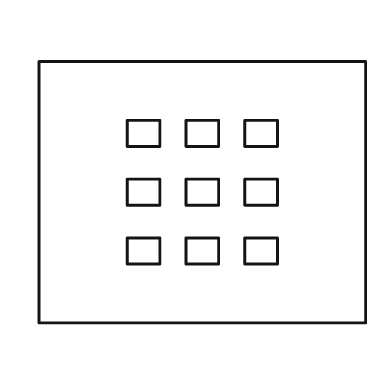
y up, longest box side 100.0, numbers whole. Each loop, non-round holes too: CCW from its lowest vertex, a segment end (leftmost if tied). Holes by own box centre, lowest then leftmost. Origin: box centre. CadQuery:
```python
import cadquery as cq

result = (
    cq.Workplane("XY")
    .moveTo(-50.0, -40.0)
    .lineTo(50.0, -40.0)
    .lineTo(50.0, 40.0)
    .lineTo(-50.0, 40.0)
    .close()
    .moveTo(-23.0, -22.0)
    .lineTo(-13.0, -22.0)
    .lineTo(-13.0, -14.0)
    .lineTo(-23.0, -14.0)
    .close()
    .moveTo(-5.0, -22.0)
    .lineTo(5.0, -22.0)
    .lineTo(5.0, -14.0)
    .lineTo(-5.0, -14.0)
    .close()
    .moveTo(13.0, -22.0)
    .lineTo(23.0, -22.0)
    .lineTo(23.0, -14.0)
    .lineTo(13.0, -14.0)
    .close()
    .moveTo(-23.0, -4.0)
    .lineTo(-13.0, -4.0)
    .lineTo(-13.0, 4.0)
    .lineTo(-23.0, 4.0)
    .close()
    .moveTo(-5.0, -4.0)
    .lineTo(5.0, -4.0)
    .lineTo(5.0, 4.0)
    .lineTo(-5.0, 4.0)
    .close()
    .moveTo(13.0, -4.0)
    .lineTo(23.0, -4.0)
    .lineTo(23.0, 4.0)
    .lineTo(13.0, 4.0)
    .close()
    .moveTo(-23.0, 14.0)
    .lineTo(-13.0, 14.0)
    .lineTo(-13.0, 22.0)
    .lineTo(-23.0, 22.0)
    .close()
    .moveTo(-5.0, 14.0)
    .lineTo(5.0, 14.0)
    .lineTo(5.0, 22.0)
    .lineTo(-5.0, 22.0)
    .close()
    .moveTo(13.0, 14.0)
    .lineTo(23.0, 14.0)
    .lineTo(23.0, 22.0)
    .lineTo(13.0, 22.0)
    .close()
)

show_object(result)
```